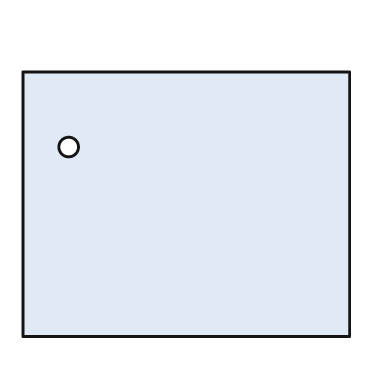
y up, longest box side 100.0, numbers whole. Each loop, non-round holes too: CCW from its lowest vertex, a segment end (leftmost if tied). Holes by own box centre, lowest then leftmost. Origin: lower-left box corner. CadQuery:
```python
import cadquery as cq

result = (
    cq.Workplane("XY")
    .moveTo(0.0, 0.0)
    .lineTo(100.0, 0.0)
    .lineTo(100.0, 81.0)
    .lineTo(0.0, 81.0)
    .close()
    .moveTo(14.0, 58.0)
    .circle(3.0)
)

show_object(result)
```